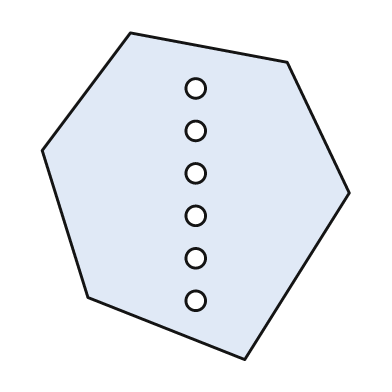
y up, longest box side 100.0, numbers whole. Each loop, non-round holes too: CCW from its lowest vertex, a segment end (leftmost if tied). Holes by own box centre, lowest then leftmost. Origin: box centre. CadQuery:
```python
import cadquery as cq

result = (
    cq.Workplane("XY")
    .moveTo(15.0, -50.0)
    .lineTo(47.0, 1.0)
    .lineTo(28.0, 41.0)
    .lineTo(-20.0, 50.0)
    .lineTo(-47.0, 14.0)
    .lineTo(-33.0, -31.0)
    .close()
    .moveTo(0.0, -32.0)
    .circle(3.0)
    .moveTo(0.0, -19.0)
    .circle(3.0)
    .moveTo(0.0, -6.0)
    .circle(3.0)
    .moveTo(0.0, 7.0)
    .circle(3.0)
    .moveTo(0.0, 20.0)
    .circle(3.0)
    .moveTo(0.0, 33.0)
    .circle(3.0)
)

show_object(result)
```